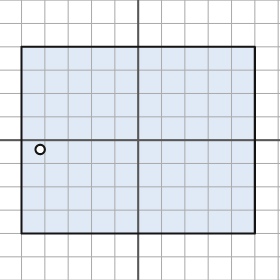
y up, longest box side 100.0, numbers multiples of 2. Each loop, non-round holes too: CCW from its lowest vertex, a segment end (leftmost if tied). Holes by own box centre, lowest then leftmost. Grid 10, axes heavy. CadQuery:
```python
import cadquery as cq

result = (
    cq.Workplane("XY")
    .moveTo(-50.0, -40.0)
    .lineTo(50.0, -40.0)
    .lineTo(50.0, 40.0)
    .lineTo(-50.0, 40.0)
    .close()
    .moveTo(-42.0, -4.0)
    .circle(2.0)
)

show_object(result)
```